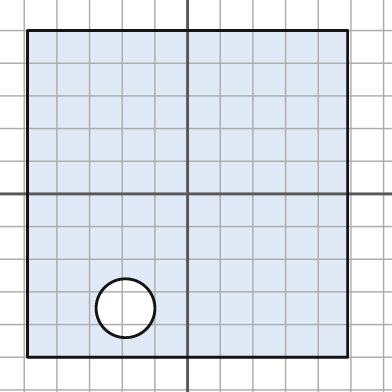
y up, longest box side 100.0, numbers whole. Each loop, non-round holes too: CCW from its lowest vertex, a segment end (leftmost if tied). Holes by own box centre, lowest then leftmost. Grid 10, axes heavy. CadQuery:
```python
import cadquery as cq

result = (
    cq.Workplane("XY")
    .moveTo(-49.0, -50.0)
    .lineTo(49.0, -50.0)
    .lineTo(49.0, 50.0)
    .lineTo(-49.0, 50.0)
    .close()
    .moveTo(-19.0, -35.0)
    .circle(9.0)
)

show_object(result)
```